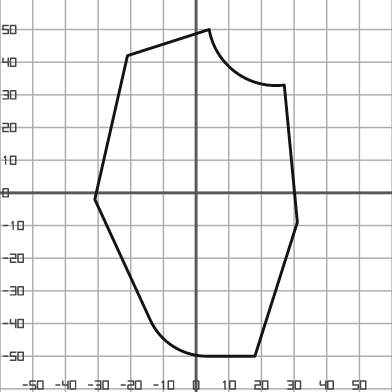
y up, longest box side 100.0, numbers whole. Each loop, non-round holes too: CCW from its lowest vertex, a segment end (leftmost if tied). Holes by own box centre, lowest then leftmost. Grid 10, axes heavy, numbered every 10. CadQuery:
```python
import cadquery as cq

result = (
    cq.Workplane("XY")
    .moveTo(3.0, -50.0)
    .lineTo(18.0, -50.0)
    .lineTo(31.0, -9.0)
    .lineTo(27.0, 33.0)
    .threePointArc((12.0, 37.0), (4.0, 50.0))
    .lineTo(-21.0, 42.0)
    .lineTo(-31.0, -2.0)
    .lineTo(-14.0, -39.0)
    .threePointArc((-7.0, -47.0), (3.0, -50.0))
    .close()
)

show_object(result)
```